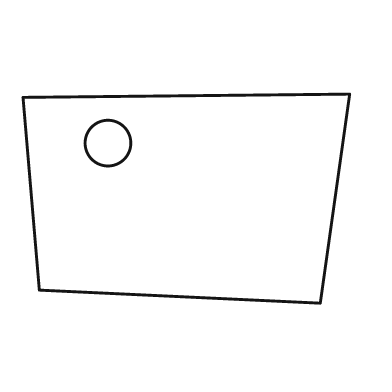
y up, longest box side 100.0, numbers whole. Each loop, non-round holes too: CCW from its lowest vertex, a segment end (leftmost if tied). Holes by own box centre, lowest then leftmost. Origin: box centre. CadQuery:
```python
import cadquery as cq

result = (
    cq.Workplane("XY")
    .moveTo(41.0, -32.0)
    .lineTo(50.0, 32.0)
    .lineTo(-50.0, 31.0)
    .lineTo(-45.0, -28.0)
    .close()
    .moveTo(-24.0, 17.0)
    .circle(7.0)
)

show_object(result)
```